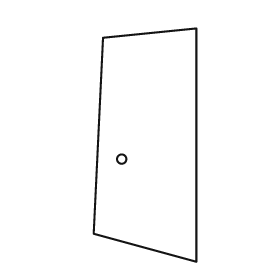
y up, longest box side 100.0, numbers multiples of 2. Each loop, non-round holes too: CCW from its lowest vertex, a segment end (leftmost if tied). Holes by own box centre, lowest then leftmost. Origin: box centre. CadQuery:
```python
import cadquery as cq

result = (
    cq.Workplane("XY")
    .moveTo(22.0, -50.0)
    .lineTo(22.0, 50.0)
    .lineTo(-18.0, 46.0)
    .lineTo(-22.0, -38.0)
    .close()
    .moveTo(-10.0, -6.0)
    .circle(2.0)
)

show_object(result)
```